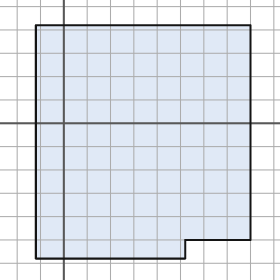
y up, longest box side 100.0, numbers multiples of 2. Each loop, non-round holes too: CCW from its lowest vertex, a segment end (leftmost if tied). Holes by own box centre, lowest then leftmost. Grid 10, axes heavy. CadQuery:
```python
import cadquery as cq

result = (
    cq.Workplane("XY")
    .moveTo(-12.0, -58.0)
    .lineTo(52.0, -58.0)
    .lineTo(52.0, -50.0)
    .lineTo(80.0, -50.0)
    .lineTo(80.0, 42.0)
    .lineTo(-12.0, 42.0)
    .close()
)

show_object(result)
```